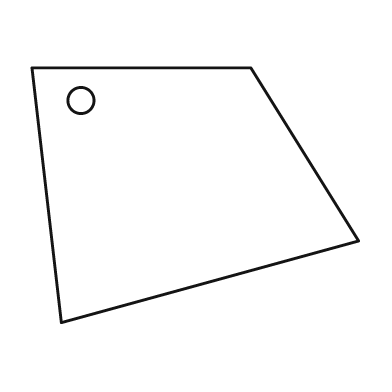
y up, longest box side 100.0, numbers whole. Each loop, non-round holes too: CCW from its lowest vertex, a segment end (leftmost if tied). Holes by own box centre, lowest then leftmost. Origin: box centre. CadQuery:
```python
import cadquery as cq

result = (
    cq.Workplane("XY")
    .moveTo(-41.0, -39.0)
    .lineTo(50.0, -14.0)
    .lineTo(17.0, 39.0)
    .lineTo(-50.0, 39.0)
    .close()
    .moveTo(-35.0, 29.0)
    .circle(4.0)
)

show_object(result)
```